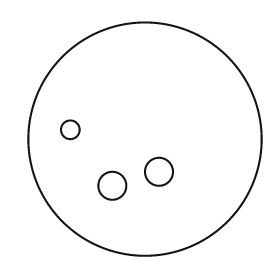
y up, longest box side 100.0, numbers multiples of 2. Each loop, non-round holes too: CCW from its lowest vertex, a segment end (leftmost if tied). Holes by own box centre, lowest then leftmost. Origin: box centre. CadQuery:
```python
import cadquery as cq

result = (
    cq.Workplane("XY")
    .moveTo(0.0, 0.0)
    .circle(50.0)
    .moveTo(-14.0, -20.0)
    .circle(6.0)
    .moveTo(6.0, -14.0)
    .circle(6.0)
    .moveTo(-32.0, 4.0)
    .circle(4.0)
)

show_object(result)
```